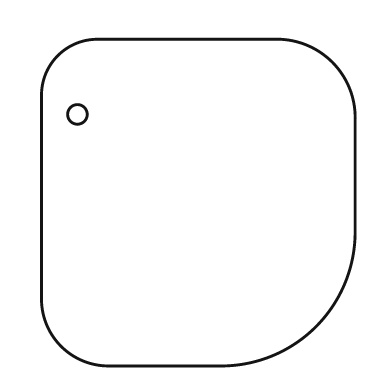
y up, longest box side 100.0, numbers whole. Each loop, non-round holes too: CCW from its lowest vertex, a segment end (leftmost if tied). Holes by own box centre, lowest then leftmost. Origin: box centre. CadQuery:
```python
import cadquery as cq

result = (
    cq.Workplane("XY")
    .moveTo(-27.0, -50.0)
    .lineTo(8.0, -50.0)
    .threePointArc((36.0, -38.0), (48.0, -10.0))
    .lineTo(48.0, 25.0)
    .threePointArc((41.0, 43.0), (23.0, 50.0))
    .lineTo(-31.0, 50.0)
    .threePointArc((-43.0, 45.0), (-48.0, 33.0))
    .lineTo(-48.0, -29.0)
    .threePointArc((-42.0, -44.0), (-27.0, -50.0))
    .close()
    .moveTo(-37.0, 27.0)
    .circle(3.0)
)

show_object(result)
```